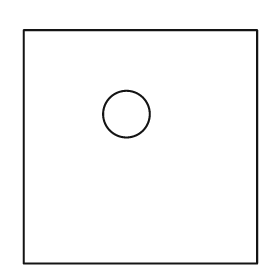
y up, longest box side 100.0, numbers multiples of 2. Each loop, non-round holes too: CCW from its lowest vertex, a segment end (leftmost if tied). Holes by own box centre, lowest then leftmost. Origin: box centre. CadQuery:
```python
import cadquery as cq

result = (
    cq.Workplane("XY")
    .moveTo(-50.0, -50.0)
    .lineTo(50.0, -50.0)
    .lineTo(50.0, 50.0)
    .lineTo(-50.0, 50.0)
    .close()
    .moveTo(-6.0, 14.0)
    .circle(10.0)
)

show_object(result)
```